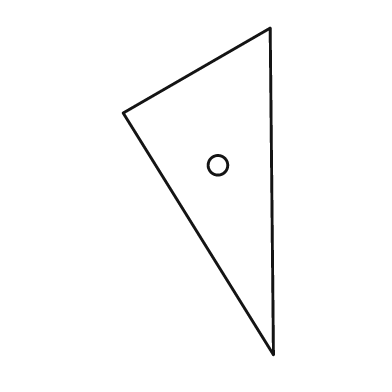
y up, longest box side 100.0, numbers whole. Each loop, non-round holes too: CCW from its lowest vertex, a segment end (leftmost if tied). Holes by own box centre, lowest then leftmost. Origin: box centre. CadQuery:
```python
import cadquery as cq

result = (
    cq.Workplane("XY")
    .moveTo(23.0, -50.0)
    .lineTo(22.0, 50.0)
    .lineTo(-23.0, 24.0)
    .close()
    .moveTo(6.0, 8.0)
    .circle(3.0)
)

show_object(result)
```